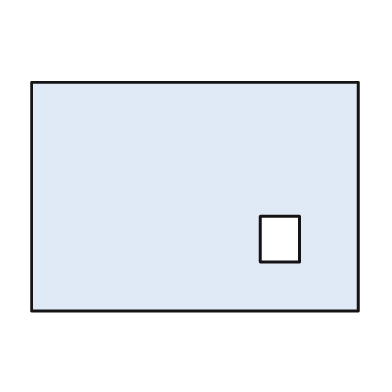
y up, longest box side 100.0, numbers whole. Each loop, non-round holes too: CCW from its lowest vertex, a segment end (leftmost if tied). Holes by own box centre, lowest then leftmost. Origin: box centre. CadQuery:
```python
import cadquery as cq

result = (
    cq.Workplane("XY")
    .moveTo(-50.0, -35.0)
    .lineTo(50.0, -35.0)
    .lineTo(50.0, 35.0)
    .lineTo(-50.0, 35.0)
    .close()
    .moveTo(20.0, -20.0)
    .lineTo(32.0, -20.0)
    .lineTo(32.0, -6.0)
    .lineTo(20.0, -6.0)
    .close()
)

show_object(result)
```